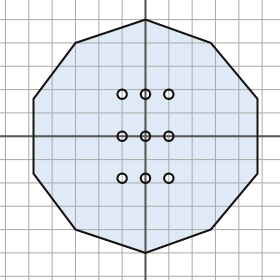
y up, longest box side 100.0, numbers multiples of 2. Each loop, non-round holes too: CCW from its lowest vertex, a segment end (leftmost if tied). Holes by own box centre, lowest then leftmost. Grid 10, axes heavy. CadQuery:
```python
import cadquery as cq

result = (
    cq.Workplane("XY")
    .moveTo(0.0, -50.0)
    .lineTo(28.0, -40.0)
    .lineTo(48.0, -16.0)
    .lineTo(48.0, 16.0)
    .lineTo(28.0, 40.0)
    .lineTo(0.0, 50.0)
    .lineTo(-30.0, 40.0)
    .lineTo(-48.0, 16.0)
    .lineTo(-48.0, -16.0)
    .lineTo(-30.0, -40.0)
    .close()
    .moveTo(-10.0, -18.0)
    .circle(2.0)
    .moveTo(0.0, -18.0)
    .circle(2.0)
    .moveTo(10.0, -18.0)
    .circle(2.0)
    .moveTo(-10.0, 0.0)
    .circle(2.0)
    .moveTo(0.0, 0.0)
    .circle(2.0)
    .moveTo(10.0, 0.0)
    .circle(2.0)
    .moveTo(-10.0, 18.0)
    .circle(2.0)
    .moveTo(0.0, 18.0)
    .circle(2.0)
    .moveTo(10.0, 18.0)
    .circle(2.0)
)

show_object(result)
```